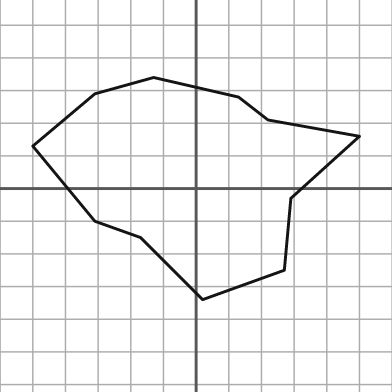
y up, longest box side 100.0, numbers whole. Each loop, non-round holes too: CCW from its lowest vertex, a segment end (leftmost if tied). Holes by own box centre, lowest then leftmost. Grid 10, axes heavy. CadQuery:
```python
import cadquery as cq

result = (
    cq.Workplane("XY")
    .moveTo(2.0, -34.0)
    .lineTo(27.0, -25.0)
    .lineTo(29.0, -3.0)
    .lineTo(50.0, 16.0)
    .lineTo(22.0, 21.0)
    .lineTo(13.0, 28.0)
    .lineTo(-13.0, 34.0)
    .lineTo(-31.0, 29.0)
    .lineTo(-50.0, 13.0)
    .lineTo(-31.0, -10.0)
    .lineTo(-17.0, -15.0)
    .close()
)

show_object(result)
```